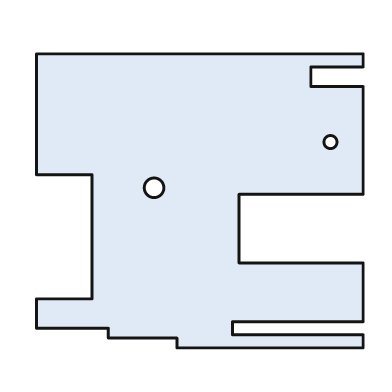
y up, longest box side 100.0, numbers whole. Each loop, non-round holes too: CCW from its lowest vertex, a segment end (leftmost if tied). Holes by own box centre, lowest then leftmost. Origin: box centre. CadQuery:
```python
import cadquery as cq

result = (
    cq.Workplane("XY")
    .moveTo(-7.0, -45.0)
    .lineTo(50.0, -45.0)
    .lineTo(50.0, -41.0)
    .lineTo(10.0, -41.0)
    .lineTo(10.0, -37.0)
    .lineTo(50.0, -37.0)
    .lineTo(50.0, -19.0)
    .lineTo(12.0, -19.0)
    .lineTo(12.0, 2.0)
    .lineTo(50.0, 2.0)
    .lineTo(50.0, 35.0)
    .lineTo(34.0, 35.0)
    .lineTo(34.0, 41.0)
    .lineTo(50.0, 41.0)
    .lineTo(50.0, 45.0)
    .lineTo(-50.0, 45.0)
    .lineTo(-50.0, 8.0)
    .lineTo(-33.0, 8.0)
    .lineTo(-33.0, -30.0)
    .lineTo(-50.0, -30.0)
    .lineTo(-50.0, -39.0)
    .lineTo(-28.0, -39.0)
    .lineTo(-28.0, -42.0)
    .lineTo(-7.0, -42.0)
    .close()
    .moveTo(-14.0, 4.0)
    .circle(3.0)
    .moveTo(40.0, 18.0)
    .circle(2.0)
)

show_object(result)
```